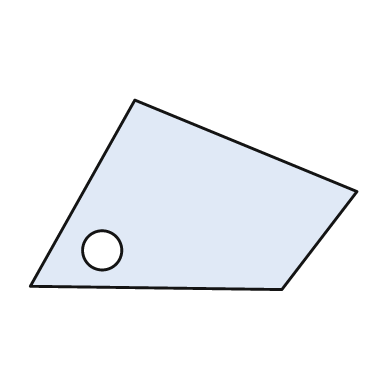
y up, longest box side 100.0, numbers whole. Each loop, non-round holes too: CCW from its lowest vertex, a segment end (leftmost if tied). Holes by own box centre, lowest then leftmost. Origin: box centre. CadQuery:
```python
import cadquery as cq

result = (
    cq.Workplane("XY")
    .moveTo(27.0, -29.0)
    .lineTo(50.0, 1.0)
    .lineTo(-18.0, 29.0)
    .lineTo(-50.0, -28.0)
    .close()
    .moveTo(-28.0, -17.0)
    .circle(6.0)
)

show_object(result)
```